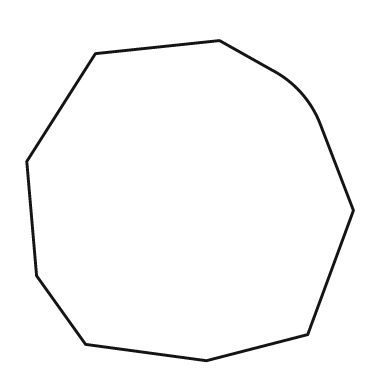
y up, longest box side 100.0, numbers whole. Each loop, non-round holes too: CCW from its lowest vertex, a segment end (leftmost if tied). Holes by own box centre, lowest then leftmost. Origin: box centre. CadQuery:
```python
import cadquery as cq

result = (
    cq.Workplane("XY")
    .moveTo(5.0, -49.0)
    .lineTo(36.0, -41.0)
    .lineTo(50.0, -3.0)
    .lineTo(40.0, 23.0)
    .threePointArc((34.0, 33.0), (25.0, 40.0))
    .lineTo(9.0, 49.0)
    .lineTo(-29.0, 45.0)
    .lineTo(-50.0, 12.0)
    .lineTo(-47.0, -23.0)
    .lineTo(-32.0, -44.0)
    .close()
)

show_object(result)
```